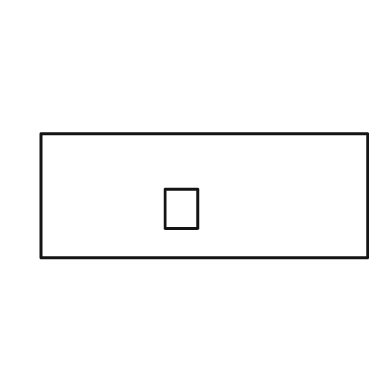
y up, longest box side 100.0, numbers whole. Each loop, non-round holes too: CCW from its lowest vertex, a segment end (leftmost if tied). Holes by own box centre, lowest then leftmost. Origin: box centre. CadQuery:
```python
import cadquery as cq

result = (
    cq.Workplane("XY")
    .moveTo(-50.0, -19.0)
    .lineTo(50.0, -19.0)
    .lineTo(50.0, 19.0)
    .lineTo(-50.0, 19.0)
    .close()
    .moveTo(-12.0, -10.0)
    .lineTo(-2.0, -10.0)
    .lineTo(-2.0, 2.0)
    .lineTo(-12.0, 2.0)
    .close()
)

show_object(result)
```